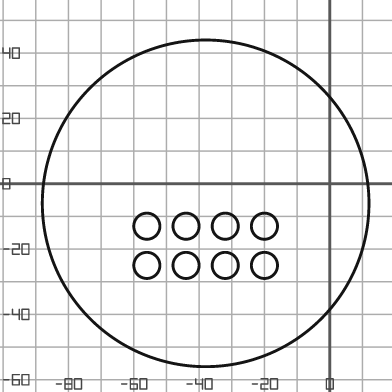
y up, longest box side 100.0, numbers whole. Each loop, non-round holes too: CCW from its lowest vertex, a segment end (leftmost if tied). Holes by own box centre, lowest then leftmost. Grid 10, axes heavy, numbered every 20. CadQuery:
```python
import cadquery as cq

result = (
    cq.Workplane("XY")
    .moveTo(-38.0, -6.0)
    .circle(50.0)
    .moveTo(-56.0, -25.0)
    .circle(4.0)
    .moveTo(-44.0, -25.0)
    .circle(4.0)
    .moveTo(-32.0, -25.0)
    .circle(4.0)
    .moveTo(-20.0, -25.0)
    .circle(4.0)
    .moveTo(-56.0, -13.0)
    .circle(4.0)
    .moveTo(-44.0, -13.0)
    .circle(4.0)
    .moveTo(-32.0, -13.0)
    .circle(4.0)
    .moveTo(-20.0, -13.0)
    .circle(4.0)
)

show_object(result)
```